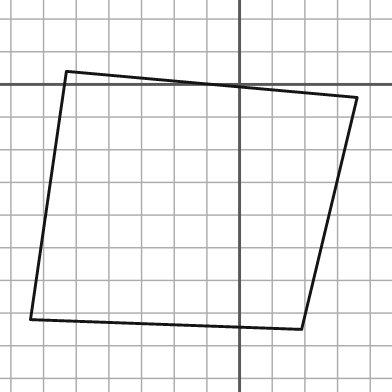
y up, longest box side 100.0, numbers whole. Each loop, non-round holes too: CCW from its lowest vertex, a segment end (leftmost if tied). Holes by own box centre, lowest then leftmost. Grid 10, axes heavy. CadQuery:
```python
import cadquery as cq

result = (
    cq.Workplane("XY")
    .moveTo(19.0, -75.0)
    .lineTo(36.0, -4.0)
    .lineTo(-53.0, 4.0)
    .lineTo(-64.0, -72.0)
    .close()
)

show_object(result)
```